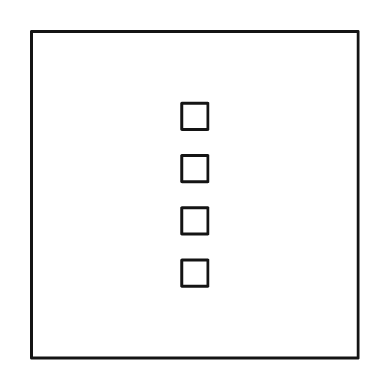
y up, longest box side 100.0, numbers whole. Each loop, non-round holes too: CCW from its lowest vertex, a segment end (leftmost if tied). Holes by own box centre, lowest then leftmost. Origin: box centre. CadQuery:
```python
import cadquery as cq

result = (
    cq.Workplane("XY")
    .moveTo(-50.0, -50.0)
    .lineTo(50.0, -50.0)
    .lineTo(50.0, 50.0)
    .lineTo(-50.0, 50.0)
    .close()
    .moveTo(-4.0, -28.0)
    .lineTo(4.0, -28.0)
    .lineTo(4.0, -20.0)
    .lineTo(-4.0, -20.0)
    .close()
    .moveTo(-4.0, -12.0)
    .lineTo(4.0, -12.0)
    .lineTo(4.0, -4.0)
    .lineTo(-4.0, -4.0)
    .close()
    .moveTo(-4.0, 4.0)
    .lineTo(4.0, 4.0)
    .lineTo(4.0, 12.0)
    .lineTo(-4.0, 12.0)
    .close()
    .moveTo(-4.0, 20.0)
    .lineTo(4.0, 20.0)
    .lineTo(4.0, 28.0)
    .lineTo(-4.0, 28.0)
    .close()
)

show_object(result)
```